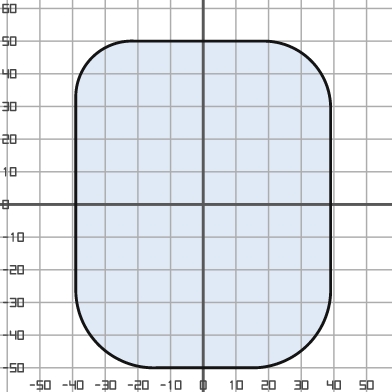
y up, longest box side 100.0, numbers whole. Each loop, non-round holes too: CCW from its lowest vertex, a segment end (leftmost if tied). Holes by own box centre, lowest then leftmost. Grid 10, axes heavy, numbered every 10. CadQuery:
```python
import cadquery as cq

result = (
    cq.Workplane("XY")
    .moveTo(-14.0, -50.0)
    .lineTo(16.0, -50.0)
    .threePointArc((32.0, -43.0), (39.0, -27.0))
    .lineTo(39.0, 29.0)
    .threePointArc((33.0, 44.0), (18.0, 50.0))
    .lineTo(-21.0, 50.0)
    .threePointArc((-34.0, 45.0), (-39.0, 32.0))
    .lineTo(-39.0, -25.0)
    .threePointArc((-32.0, -43.0), (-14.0, -50.0))
    .close()
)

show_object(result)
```